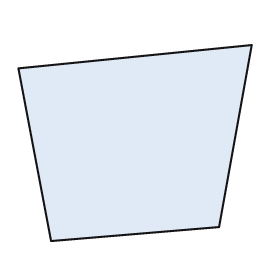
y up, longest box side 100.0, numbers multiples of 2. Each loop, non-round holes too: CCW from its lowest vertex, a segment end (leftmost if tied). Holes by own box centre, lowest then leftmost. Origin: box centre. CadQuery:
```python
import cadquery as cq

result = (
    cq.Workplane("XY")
    .moveTo(-36.0, -42.0)
    .lineTo(36.0, -36.0)
    .lineTo(50.0, 42.0)
    .lineTo(-50.0, 32.0)
    .close()
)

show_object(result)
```